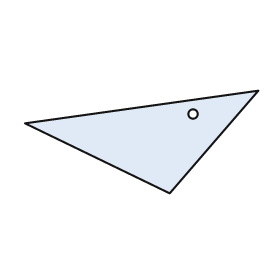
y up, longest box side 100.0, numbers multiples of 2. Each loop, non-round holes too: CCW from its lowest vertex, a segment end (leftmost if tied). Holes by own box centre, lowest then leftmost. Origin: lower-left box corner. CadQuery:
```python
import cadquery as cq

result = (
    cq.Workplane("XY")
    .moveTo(62.0, 0.0)
    .lineTo(100.0, 44.0)
    .lineTo(0.0, 30.0)
    .close()
    .moveTo(72.0, 34.0)
    .circle(2.0)
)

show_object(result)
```